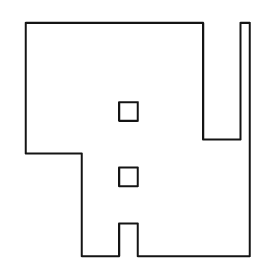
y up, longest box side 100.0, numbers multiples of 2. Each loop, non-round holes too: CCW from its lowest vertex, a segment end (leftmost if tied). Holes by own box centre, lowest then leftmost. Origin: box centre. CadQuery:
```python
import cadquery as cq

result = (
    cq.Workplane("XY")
    .moveTo(-24.0, -50.0)
    .lineTo(-8.0, -50.0)
    .lineTo(-8.0, -36.0)
    .lineTo(0.0, -36.0)
    .lineTo(0.0, -50.0)
    .lineTo(48.0, -50.0)
    .lineTo(48.0, 50.0)
    .lineTo(44.0, 50.0)
    .lineTo(44.0, 0.0)
    .lineTo(28.0, 0.0)
    .lineTo(28.0, 50.0)
    .lineTo(-48.0, 50.0)
    .lineTo(-48.0, -6.0)
    .lineTo(-24.0, -6.0)
    .close()
    .moveTo(-8.0, -20.0)
    .lineTo(0.0, -20.0)
    .lineTo(0.0, -12.0)
    .lineTo(-8.0, -12.0)
    .close()
    .moveTo(-8.0, 8.0)
    .lineTo(0.0, 8.0)
    .lineTo(0.0, 16.0)
    .lineTo(-8.0, 16.0)
    .close()
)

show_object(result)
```